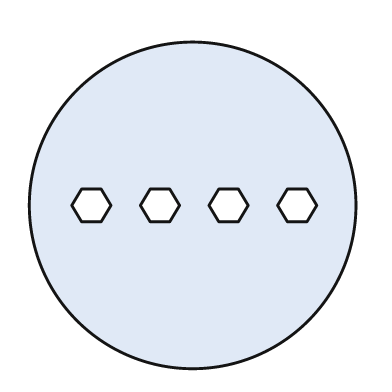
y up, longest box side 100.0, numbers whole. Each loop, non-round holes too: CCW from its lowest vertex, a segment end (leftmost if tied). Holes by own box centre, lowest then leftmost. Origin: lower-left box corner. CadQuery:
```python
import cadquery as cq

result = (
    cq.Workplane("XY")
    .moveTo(50.0, 50.0)
    .circle(50.0)
    .moveTo(16.0, 45.0)
    .lineTo(22.0, 45.0)
    .lineTo(25.0, 50.0)
    .lineTo(22.0, 55.0)
    .lineTo(16.0, 55.0)
    .lineTo(13.0, 50.0)
    .close()
    .moveTo(37.0, 45.0)
    .lineTo(43.0, 45.0)
    .lineTo(46.0, 50.0)
    .lineTo(43.0, 55.0)
    .lineTo(37.0, 55.0)
    .lineTo(34.0, 50.0)
    .close()
    .moveTo(58.0, 45.0)
    .lineTo(64.0, 45.0)
    .lineTo(67.0, 50.0)
    .lineTo(64.0, 55.0)
    .lineTo(58.0, 55.0)
    .lineTo(55.0, 50.0)
    .close()
    .moveTo(79.0, 45.0)
    .lineTo(85.0, 45.0)
    .lineTo(88.0, 50.0)
    .lineTo(85.0, 55.0)
    .lineTo(79.0, 55.0)
    .lineTo(76.0, 50.0)
    .close()
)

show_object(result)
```